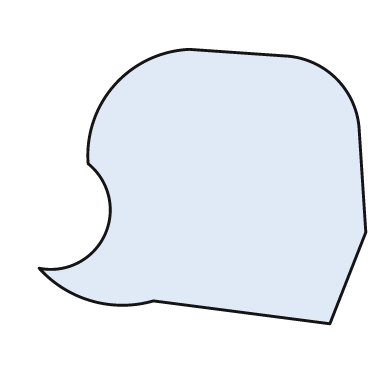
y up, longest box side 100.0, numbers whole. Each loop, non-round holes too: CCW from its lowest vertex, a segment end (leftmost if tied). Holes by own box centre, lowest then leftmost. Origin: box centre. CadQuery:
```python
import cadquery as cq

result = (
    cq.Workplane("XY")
    .moveTo(39.0, -42.0)
    .lineTo(50.0, -14.0)
    .lineTo(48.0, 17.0)
    .threePointArc((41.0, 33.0), (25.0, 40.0))
    .lineTo(-4.0, 42.0)
    .threePointArc((-27.0, 31.0), (-35.0, 7.0))
    .threePointArc((-30.0, -15.0), (-50.0, -25.0))
    .threePointArc((-34.0, -35.0), (-15.0, -35.0))
    .close()
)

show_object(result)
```